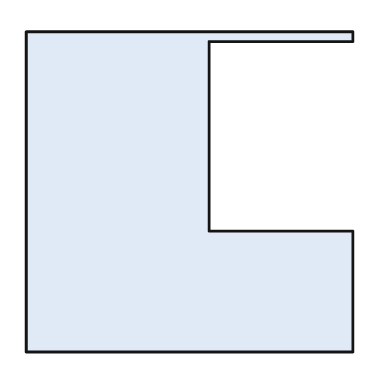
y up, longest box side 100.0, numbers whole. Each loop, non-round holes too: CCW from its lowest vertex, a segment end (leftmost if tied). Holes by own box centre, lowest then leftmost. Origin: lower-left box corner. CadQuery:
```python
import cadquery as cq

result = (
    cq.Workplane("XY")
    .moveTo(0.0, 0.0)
    .lineTo(100.0, 0.0)
    .lineTo(100.0, 37.0)
    .lineTo(56.0, 37.0)
    .lineTo(56.0, 95.0)
    .lineTo(100.0, 95.0)
    .lineTo(100.0, 98.0)
    .lineTo(0.0, 98.0)
    .close()
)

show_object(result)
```